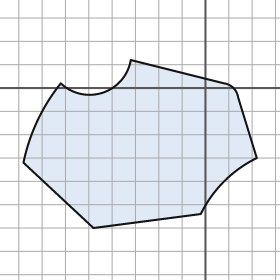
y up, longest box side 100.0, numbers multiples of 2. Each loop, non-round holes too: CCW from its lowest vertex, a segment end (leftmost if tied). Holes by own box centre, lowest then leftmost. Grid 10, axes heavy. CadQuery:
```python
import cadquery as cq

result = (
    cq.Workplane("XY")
    .moveTo(-48.0, -60.0)
    .lineTo(-2.0, -54.0)
    .threePointArc((8.0, -40.0), (22.0, -30.0))
    .lineTo(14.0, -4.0)
    .threePointArc((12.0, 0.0), (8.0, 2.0))
    .lineTo(-32.0, 12.0)
    .threePointArc((-44.0, -2.0), (-62.0, 2.0))
    .threePointArc((-72.0, -14.0), (-78.0, -32.0))
    .close()
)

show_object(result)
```